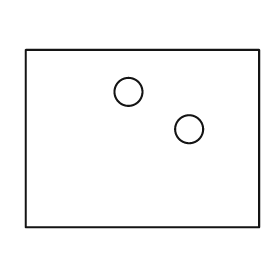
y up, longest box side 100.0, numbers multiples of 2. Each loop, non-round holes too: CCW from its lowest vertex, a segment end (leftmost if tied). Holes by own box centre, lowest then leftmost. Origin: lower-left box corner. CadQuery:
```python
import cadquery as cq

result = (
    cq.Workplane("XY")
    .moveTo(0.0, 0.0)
    .lineTo(100.0, 0.0)
    .lineTo(100.0, 76.0)
    .lineTo(0.0, 76.0)
    .close()
    .moveTo(70.0, 42.0)
    .circle(6.0)
    .moveTo(44.0, 58.0)
    .circle(6.0)
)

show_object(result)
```